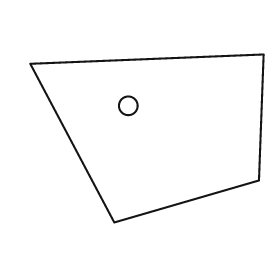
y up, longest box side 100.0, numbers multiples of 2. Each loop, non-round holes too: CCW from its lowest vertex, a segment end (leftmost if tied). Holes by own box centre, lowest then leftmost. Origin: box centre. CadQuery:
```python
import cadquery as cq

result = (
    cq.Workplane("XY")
    .moveTo(-14.0, -36.0)
    .lineTo(48.0, -18.0)
    .lineTo(50.0, 36.0)
    .lineTo(-50.0, 32.0)
    .close()
    .moveTo(-8.0, 14.0)
    .circle(4.0)
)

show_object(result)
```